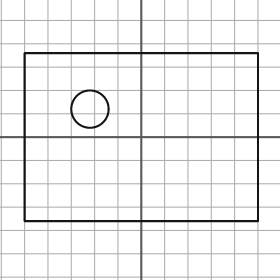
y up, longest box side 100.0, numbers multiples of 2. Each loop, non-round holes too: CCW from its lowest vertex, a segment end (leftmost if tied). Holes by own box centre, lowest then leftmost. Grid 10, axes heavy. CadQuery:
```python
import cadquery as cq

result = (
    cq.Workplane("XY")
    .moveTo(-50.0, -36.0)
    .lineTo(50.0, -36.0)
    .lineTo(50.0, 36.0)
    .lineTo(-50.0, 36.0)
    .close()
    .moveTo(-22.0, 12.0)
    .circle(8.0)
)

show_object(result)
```